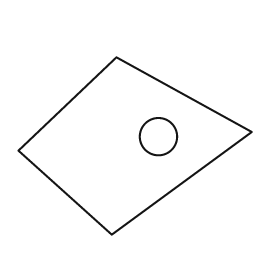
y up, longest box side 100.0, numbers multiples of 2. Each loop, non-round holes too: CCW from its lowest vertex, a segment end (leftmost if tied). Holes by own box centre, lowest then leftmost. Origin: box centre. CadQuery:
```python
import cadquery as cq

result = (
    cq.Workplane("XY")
    .moveTo(-10.0, -38.0)
    .lineTo(50.0, 6.0)
    .lineTo(-8.0, 38.0)
    .lineTo(-50.0, -2.0)
    .close()
    .moveTo(10.0, 4.0)
    .circle(8.0)
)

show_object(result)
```